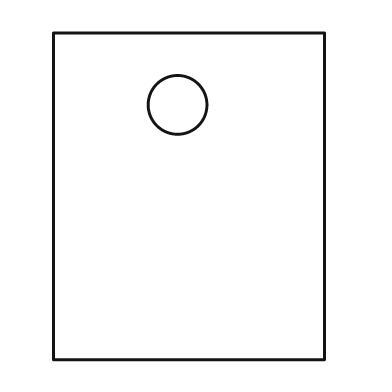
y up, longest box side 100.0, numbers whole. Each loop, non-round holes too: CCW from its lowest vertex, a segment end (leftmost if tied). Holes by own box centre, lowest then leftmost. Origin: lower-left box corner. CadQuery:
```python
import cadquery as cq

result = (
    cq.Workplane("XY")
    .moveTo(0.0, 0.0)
    .lineTo(83.0, 0.0)
    .lineTo(83.0, 100.0)
    .lineTo(0.0, 100.0)
    .close()
    .moveTo(38.0, 78.0)
    .circle(9.0)
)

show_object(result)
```